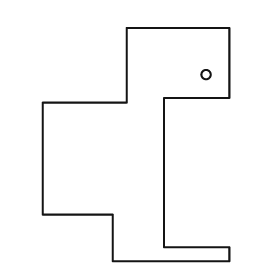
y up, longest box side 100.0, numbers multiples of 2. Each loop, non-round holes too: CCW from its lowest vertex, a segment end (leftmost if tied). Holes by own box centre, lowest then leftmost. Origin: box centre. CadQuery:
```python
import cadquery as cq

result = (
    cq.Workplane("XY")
    .moveTo(-10.0, -50.0)
    .lineTo(40.0, -50.0)
    .lineTo(40.0, -44.0)
    .lineTo(12.0, -44.0)
    .lineTo(12.0, 20.0)
    .lineTo(40.0, 20.0)
    .lineTo(40.0, 50.0)
    .lineTo(-4.0, 50.0)
    .lineTo(-4.0, 18.0)
    .lineTo(-40.0, 18.0)
    .lineTo(-40.0, -30.0)
    .lineTo(-10.0, -30.0)
    .close()
    .moveTo(30.0, 30.0)
    .circle(2.0)
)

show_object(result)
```